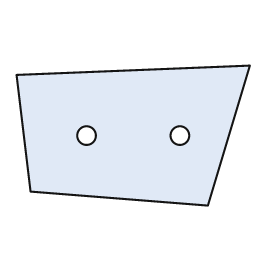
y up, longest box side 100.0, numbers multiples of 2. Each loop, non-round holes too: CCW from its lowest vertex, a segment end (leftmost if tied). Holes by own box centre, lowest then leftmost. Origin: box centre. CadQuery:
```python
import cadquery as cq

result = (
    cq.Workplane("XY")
    .moveTo(32.0, -30.0)
    .lineTo(50.0, 30.0)
    .lineTo(-50.0, 26.0)
    .lineTo(-44.0, -24.0)
    .close()
    .moveTo(-20.0, 0.0)
    .circle(4.0)
    .moveTo(20.0, 0.0)
    .circle(4.0)
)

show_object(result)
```